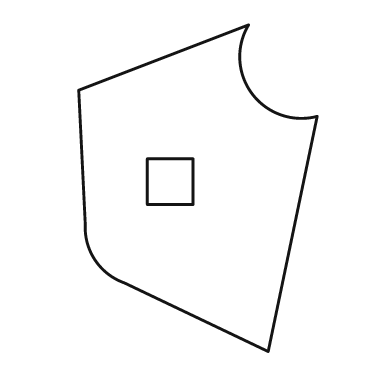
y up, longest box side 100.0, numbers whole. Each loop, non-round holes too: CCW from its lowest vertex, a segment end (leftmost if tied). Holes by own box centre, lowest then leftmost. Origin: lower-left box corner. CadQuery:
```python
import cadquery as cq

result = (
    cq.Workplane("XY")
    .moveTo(58.0, 0.0)
    .lineTo(73.0, 72.0)
    .threePointArc((53.0, 79.0), (52.0, 100.0))
    .lineTo(0.0, 80.0)
    .lineTo(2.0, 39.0)
    .threePointArc((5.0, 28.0), (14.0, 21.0))
    .close()
    .moveTo(21.0, 45.0)
    .lineTo(35.0, 45.0)
    .lineTo(35.0, 59.0)
    .lineTo(21.0, 59.0)
    .close()
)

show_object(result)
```